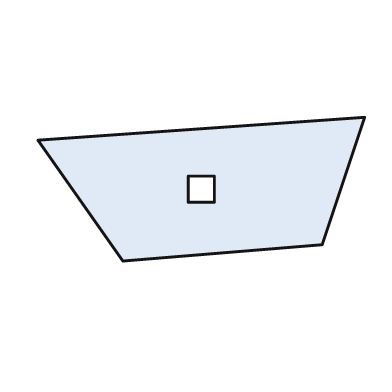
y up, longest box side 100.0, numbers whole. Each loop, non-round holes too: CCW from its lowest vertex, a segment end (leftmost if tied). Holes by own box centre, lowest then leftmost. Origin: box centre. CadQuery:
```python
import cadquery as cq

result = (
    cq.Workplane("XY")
    .moveTo(-24.0, -22.0)
    .lineTo(37.0, -17.0)
    .lineTo(50.0, 22.0)
    .lineTo(-50.0, 15.0)
    .close()
    .moveTo(-4.0, -4.0)
    .lineTo(4.0, -4.0)
    .lineTo(4.0, 4.0)
    .lineTo(-4.0, 4.0)
    .close()
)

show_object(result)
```